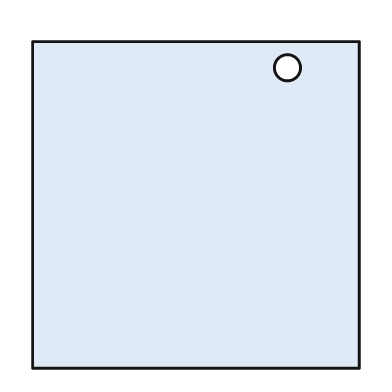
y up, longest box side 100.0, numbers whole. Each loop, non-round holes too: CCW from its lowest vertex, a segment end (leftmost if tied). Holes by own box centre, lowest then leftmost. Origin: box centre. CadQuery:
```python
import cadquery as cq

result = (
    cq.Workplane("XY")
    .moveTo(-50.0, -50.0)
    .lineTo(50.0, -50.0)
    .lineTo(50.0, 50.0)
    .lineTo(-50.0, 50.0)
    .close()
    .moveTo(28.0, 42.0)
    .circle(4.0)
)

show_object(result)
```